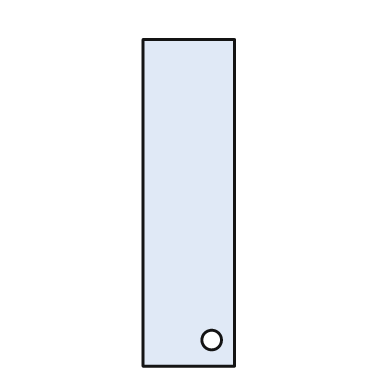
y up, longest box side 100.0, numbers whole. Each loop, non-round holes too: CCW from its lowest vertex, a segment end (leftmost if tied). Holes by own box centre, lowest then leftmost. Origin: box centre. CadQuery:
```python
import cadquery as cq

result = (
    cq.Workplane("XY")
    .moveTo(-14.0, -50.0)
    .lineTo(14.0, -50.0)
    .lineTo(14.0, 50.0)
    .lineTo(-14.0, 50.0)
    .close()
    .moveTo(7.0, -42.0)
    .circle(3.0)
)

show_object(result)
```